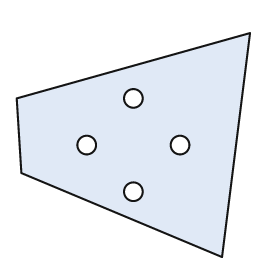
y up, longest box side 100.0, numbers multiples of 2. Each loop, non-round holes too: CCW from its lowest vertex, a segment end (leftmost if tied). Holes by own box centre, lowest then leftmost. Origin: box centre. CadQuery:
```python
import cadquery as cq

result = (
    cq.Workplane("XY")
    .moveTo(38.0, -48.0)
    .lineTo(50.0, 48.0)
    .lineTo(-50.0, 20.0)
    .lineTo(-48.0, -12.0)
    .close()
    .moveTo(0.0, -20.0)
    .circle(4.0)
    .moveTo(-20.0, 0.0)
    .circle(4.0)
    .moveTo(20.0, 0.0)
    .circle(4.0)
    .moveTo(0.0, 20.0)
    .circle(4.0)
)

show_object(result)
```